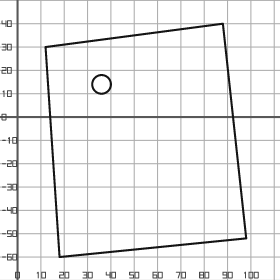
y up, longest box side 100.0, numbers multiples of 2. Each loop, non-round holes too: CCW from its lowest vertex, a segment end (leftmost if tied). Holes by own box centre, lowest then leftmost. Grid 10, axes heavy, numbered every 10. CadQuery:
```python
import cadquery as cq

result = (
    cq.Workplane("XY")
    .moveTo(18.0, -60.0)
    .lineTo(98.0, -52.0)
    .lineTo(88.0, 40.0)
    .lineTo(12.0, 30.0)
    .close()
    .moveTo(36.0, 14.0)
    .circle(4.0)
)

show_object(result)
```